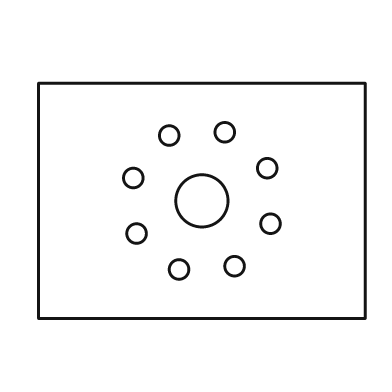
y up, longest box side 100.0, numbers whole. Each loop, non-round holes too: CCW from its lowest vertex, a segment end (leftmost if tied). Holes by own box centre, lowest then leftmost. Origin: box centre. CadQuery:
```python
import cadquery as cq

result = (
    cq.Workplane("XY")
    .moveTo(-50.0, -36.0)
    .lineTo(50.0, -36.0)
    .lineTo(50.0, 36.0)
    .lineTo(-50.0, 36.0)
    .close()
    .moveTo(-7.0, -21.0)
    .circle(3.0)
    .moveTo(10.0, -20.0)
    .circle(3.0)
    .moveTo(-20.0, -10.0)
    .circle(3.0)
    .moveTo(21.0, -7.0)
    .circle(3.0)
    .moveTo(0.0, 0.0)
    .circle(8.0)
    .moveTo(-21.0, 7.0)
    .circle(3.0)
    .moveTo(20.0, 10.0)
    .circle(3.0)
    .moveTo(-10.0, 20.0)
    .circle(3.0)
    .moveTo(7.0, 21.0)
    .circle(3.0)
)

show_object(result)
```